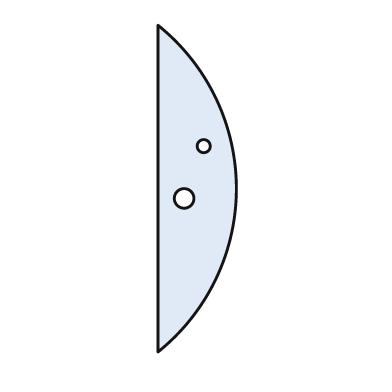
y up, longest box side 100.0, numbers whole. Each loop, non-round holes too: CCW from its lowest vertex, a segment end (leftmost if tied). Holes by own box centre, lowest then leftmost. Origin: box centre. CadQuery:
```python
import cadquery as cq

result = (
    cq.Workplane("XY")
    .moveTo(-12.0, -50.0)
    .threePointArc((12.0, 0.0), (-12.0, 50.0))
    .close()
    .moveTo(-4.0, -3.0)
    .circle(3.0)
    .moveTo(2.0, 13.0)
    .circle(2.0)
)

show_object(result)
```